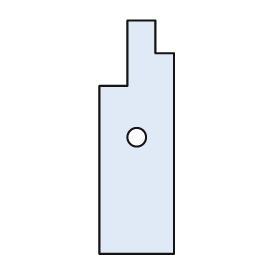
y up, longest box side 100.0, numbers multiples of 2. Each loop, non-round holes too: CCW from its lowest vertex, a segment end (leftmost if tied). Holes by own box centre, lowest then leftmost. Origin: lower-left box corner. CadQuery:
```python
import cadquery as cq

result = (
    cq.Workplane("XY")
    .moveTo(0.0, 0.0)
    .lineTo(32.0, 0.0)
    .lineTo(32.0, 86.0)
    .lineTo(24.0, 86.0)
    .lineTo(24.0, 100.0)
    .lineTo(12.0, 100.0)
    .lineTo(12.0, 72.0)
    .lineTo(0.0, 72.0)
    .close()
    .moveTo(16.0, 50.0)
    .circle(4.0)
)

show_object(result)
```